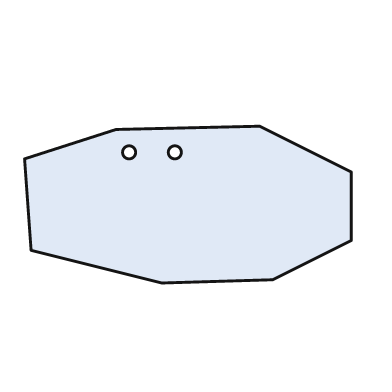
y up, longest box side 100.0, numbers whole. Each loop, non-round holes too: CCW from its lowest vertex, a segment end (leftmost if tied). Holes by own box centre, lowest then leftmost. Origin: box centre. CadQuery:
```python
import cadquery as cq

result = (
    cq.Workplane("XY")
    .moveTo(-8.0, -24.0)
    .lineTo(26.0, -23.0)
    .lineTo(50.0, -11.0)
    .lineTo(50.0, 10.0)
    .lineTo(22.0, 24.0)
    .lineTo(-22.0, 23.0)
    .lineTo(-50.0, 14.0)
    .lineTo(-48.0, -14.0)
    .close()
    .moveTo(-18.0, 16.0)
    .circle(2.0)
    .moveTo(-4.0, 16.0)
    .circle(2.0)
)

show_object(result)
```